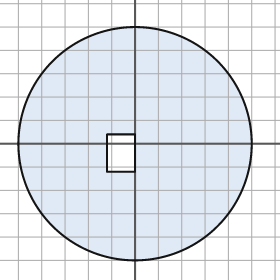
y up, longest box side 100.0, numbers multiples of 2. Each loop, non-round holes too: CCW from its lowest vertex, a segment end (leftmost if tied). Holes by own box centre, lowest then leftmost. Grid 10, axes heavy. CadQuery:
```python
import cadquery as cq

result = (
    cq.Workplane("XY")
    .moveTo(0.0, 0.0)
    .circle(50.0)
    .moveTo(-12.0, -12.0)
    .lineTo(0.0, -12.0)
    .lineTo(0.0, 4.0)
    .lineTo(-12.0, 4.0)
    .close()
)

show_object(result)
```